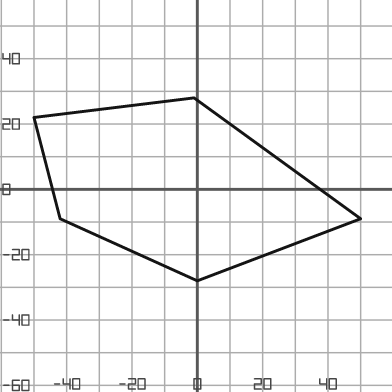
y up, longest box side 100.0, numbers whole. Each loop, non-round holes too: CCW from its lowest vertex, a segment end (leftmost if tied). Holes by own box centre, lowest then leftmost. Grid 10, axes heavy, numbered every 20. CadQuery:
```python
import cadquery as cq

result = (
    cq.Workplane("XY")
    .moveTo(0.0, -28.0)
    .lineTo(50.0, -9.0)
    .lineTo(-1.0, 28.0)
    .lineTo(-50.0, 22.0)
    .lineTo(-42.0, -9.0)
    .close()
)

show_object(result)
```